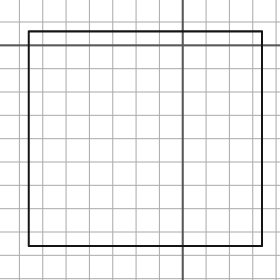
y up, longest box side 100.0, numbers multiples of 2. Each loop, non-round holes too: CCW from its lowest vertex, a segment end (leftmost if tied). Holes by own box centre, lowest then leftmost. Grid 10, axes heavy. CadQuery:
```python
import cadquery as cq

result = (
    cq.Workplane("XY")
    .moveTo(-66.0, -86.0)
    .lineTo(34.0, -86.0)
    .lineTo(34.0, 6.0)
    .lineTo(-66.0, 6.0)
    .close()
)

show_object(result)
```